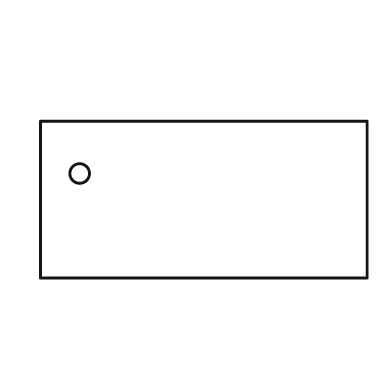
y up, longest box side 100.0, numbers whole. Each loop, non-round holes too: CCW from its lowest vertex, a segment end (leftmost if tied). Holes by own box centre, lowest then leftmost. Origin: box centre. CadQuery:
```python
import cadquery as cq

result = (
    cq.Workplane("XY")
    .moveTo(-50.0, -24.0)
    .lineTo(50.0, -24.0)
    .lineTo(50.0, 24.0)
    .lineTo(-50.0, 24.0)
    .close()
    .moveTo(-38.0, 8.0)
    .circle(3.0)
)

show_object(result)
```